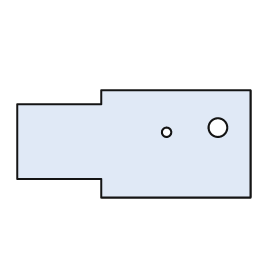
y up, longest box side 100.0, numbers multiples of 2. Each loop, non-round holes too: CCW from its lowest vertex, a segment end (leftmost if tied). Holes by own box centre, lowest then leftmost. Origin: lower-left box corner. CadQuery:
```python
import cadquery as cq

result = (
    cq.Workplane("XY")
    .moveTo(36.0, 0.0)
    .lineTo(100.0, 0.0)
    .lineTo(100.0, 46.0)
    .lineTo(36.0, 46.0)
    .lineTo(36.0, 40.0)
    .lineTo(0.0, 40.0)
    .lineTo(0.0, 8.0)
    .lineTo(36.0, 8.0)
    .close()
    .moveTo(64.0, 28.0)
    .circle(2.0)
    .moveTo(86.0, 30.0)
    .circle(4.0)
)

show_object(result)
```